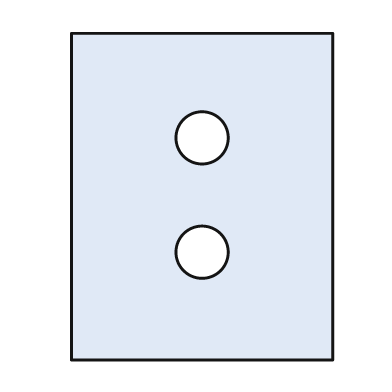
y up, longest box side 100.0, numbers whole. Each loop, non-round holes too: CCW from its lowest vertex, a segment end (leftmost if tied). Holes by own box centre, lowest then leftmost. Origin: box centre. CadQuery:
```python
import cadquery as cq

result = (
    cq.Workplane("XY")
    .moveTo(-40.0, -50.0)
    .lineTo(40.0, -50.0)
    .lineTo(40.0, 50.0)
    .lineTo(-40.0, 50.0)
    .close()
    .moveTo(0.0, -17.0)
    .circle(8.0)
    .moveTo(0.0, 18.0)
    .circle(8.0)
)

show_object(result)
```